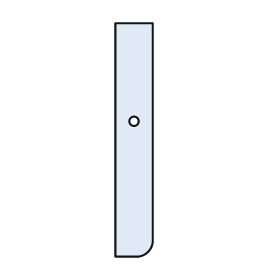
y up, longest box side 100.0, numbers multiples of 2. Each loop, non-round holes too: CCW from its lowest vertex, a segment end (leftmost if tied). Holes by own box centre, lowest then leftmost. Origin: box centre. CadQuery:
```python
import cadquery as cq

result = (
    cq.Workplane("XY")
    .moveTo(-8.0, -50.0)
    .lineTo(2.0, -50.0)
    .threePointArc((6.0, -48.0), (8.0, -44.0))
    .lineTo(8.0, 50.0)
    .lineTo(-8.0, 50.0)
    .close()
    .moveTo(0.0, 8.0)
    .circle(2.0)
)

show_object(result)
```